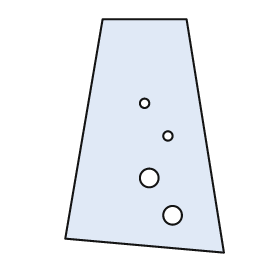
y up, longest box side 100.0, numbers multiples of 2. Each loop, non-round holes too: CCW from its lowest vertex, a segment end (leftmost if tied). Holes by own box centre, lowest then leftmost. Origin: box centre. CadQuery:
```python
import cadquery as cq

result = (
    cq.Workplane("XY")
    .moveTo(34.0, -50.0)
    .lineTo(18.0, 50.0)
    .lineTo(-18.0, 50.0)
    .lineTo(-34.0, -44.0)
    .close()
    .moveTo(12.0, -34.0)
    .circle(4.0)
    .moveTo(2.0, -18.0)
    .circle(4.0)
    .moveTo(10.0, 0.0)
    .circle(2.0)
    .moveTo(0.0, 14.0)
    .circle(2.0)
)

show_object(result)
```